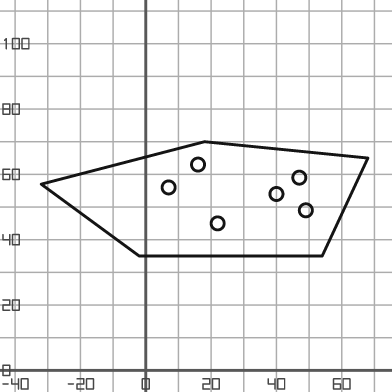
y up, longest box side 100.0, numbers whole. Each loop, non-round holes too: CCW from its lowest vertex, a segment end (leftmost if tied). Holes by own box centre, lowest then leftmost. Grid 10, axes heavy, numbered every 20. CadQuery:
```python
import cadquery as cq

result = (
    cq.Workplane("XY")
    .moveTo(-2.0, 35.0)
    .lineTo(54.0, 35.0)
    .lineTo(68.0, 65.0)
    .lineTo(18.0, 70.0)
    .lineTo(-32.0, 57.0)
    .close()
    .moveTo(22.0, 45.0)
    .circle(2.0)
    .moveTo(49.0, 49.0)
    .circle(2.0)
    .moveTo(40.0, 54.0)
    .circle(2.0)
    .moveTo(7.0, 56.0)
    .circle(2.0)
    .moveTo(47.0, 59.0)
    .circle(2.0)
    .moveTo(16.0, 63.0)
    .circle(2.0)
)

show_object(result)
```